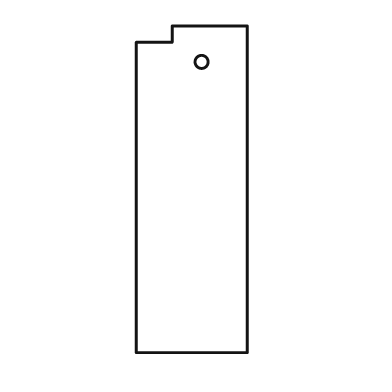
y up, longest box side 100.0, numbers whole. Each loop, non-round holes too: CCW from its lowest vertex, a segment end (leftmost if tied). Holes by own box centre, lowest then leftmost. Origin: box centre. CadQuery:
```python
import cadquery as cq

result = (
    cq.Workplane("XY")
    .moveTo(-17.0, -50.0)
    .lineTo(17.0, -50.0)
    .lineTo(17.0, 50.0)
    .lineTo(-6.0, 50.0)
    .lineTo(-6.0, 45.0)
    .lineTo(-17.0, 45.0)
    .close()
    .moveTo(3.0, 39.0)
    .circle(2.0)
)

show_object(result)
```